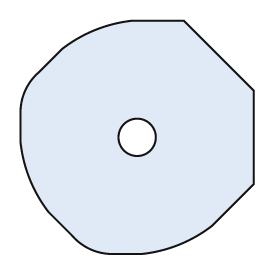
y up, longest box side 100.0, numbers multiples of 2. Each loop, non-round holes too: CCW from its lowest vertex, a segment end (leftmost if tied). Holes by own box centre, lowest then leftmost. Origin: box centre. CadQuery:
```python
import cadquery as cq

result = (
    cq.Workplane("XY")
    .moveTo(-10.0, -50.0)
    .lineTo(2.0, -50.0)
    .threePointArc((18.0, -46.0), (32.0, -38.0))
    .lineTo(50.0, -20.0)
    .lineTo(50.0, 20.0)
    .lineTo(20.0, 50.0)
    .lineTo(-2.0, 50.0)
    .threePointArc((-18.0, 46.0), (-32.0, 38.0))
    .lineTo(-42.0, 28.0)
    .threePointArc((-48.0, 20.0), (-50.0, 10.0))
    .lineTo(-50.0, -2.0)
    .threePointArc((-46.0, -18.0), (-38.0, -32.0))
    .lineTo(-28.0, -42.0)
    .threePointArc((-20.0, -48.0), (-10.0, -50.0))
    .close()
    .moveTo(0.0, 0.0)
    .circle(8.0)
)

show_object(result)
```